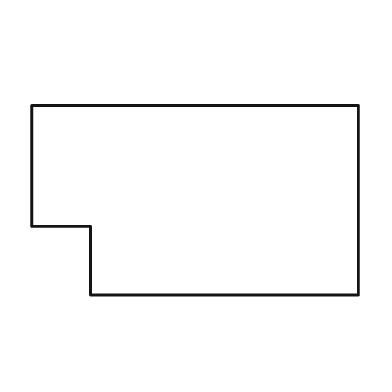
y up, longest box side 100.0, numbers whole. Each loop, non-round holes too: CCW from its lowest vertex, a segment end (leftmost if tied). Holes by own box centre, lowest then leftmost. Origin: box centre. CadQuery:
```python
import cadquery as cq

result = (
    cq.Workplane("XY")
    .moveTo(-32.0, -29.0)
    .lineTo(50.0, -29.0)
    .lineTo(50.0, 29.0)
    .lineTo(-50.0, 29.0)
    .lineTo(-50.0, -8.0)
    .lineTo(-32.0, -8.0)
    .close()
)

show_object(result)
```